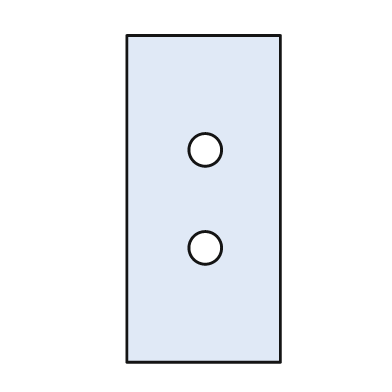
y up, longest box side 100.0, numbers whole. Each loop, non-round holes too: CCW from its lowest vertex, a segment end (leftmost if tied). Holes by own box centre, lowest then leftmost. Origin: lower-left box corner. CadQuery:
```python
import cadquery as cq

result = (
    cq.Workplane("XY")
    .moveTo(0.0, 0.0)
    .lineTo(47.0, 0.0)
    .lineTo(47.0, 100.0)
    .lineTo(0.0, 100.0)
    .close()
    .moveTo(24.0, 35.0)
    .circle(5.0)
    .moveTo(24.0, 65.0)
    .circle(5.0)
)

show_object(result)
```